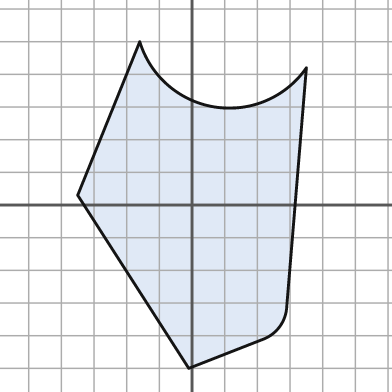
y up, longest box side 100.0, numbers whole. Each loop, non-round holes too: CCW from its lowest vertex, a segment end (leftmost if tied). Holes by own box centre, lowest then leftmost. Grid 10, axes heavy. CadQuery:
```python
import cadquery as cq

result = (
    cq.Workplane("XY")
    .moveTo(-1.0, -50.0)
    .lineTo(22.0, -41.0)
    .threePointArc((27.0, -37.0), (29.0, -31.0))
    .lineTo(35.0, 42.0)
    .threePointArc((7.0, 30.0), (-16.0, 50.0))
    .lineTo(-35.0, 3.0)
    .close()
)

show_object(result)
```